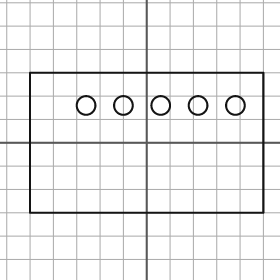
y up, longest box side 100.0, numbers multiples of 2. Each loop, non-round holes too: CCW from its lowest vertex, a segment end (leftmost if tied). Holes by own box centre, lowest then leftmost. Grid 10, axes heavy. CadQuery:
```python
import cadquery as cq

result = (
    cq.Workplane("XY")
    .moveTo(-50.0, -30.0)
    .lineTo(50.0, -30.0)
    .lineTo(50.0, 30.0)
    .lineTo(-50.0, 30.0)
    .close()
    .moveTo(-26.0, 16.0)
    .circle(4.0)
    .moveTo(-10.0, 16.0)
    .circle(4.0)
    .moveTo(6.0, 16.0)
    .circle(4.0)
    .moveTo(22.0, 16.0)
    .circle(4.0)
    .moveTo(38.0, 16.0)
    .circle(4.0)
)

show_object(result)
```